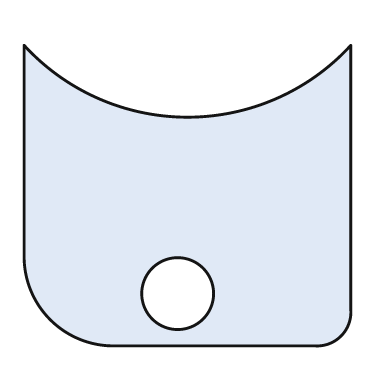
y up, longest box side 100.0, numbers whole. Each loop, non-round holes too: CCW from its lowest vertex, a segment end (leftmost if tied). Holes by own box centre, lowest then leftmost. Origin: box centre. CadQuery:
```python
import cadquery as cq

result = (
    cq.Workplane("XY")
    .moveTo(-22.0, -46.0)
    .lineTo(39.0, -46.0)
    .threePointArc((47.0, -43.0), (50.0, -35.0))
    .lineTo(50.0, 46.0)
    .threePointArc((0.0, 24.0), (-50.0, 46.0))
    .lineTo(-50.0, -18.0)
    .threePointArc((-42.0, -38.0), (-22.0, -46.0))
    .close()
    .moveTo(-3.0, -30.0)
    .circle(11.0)
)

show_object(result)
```